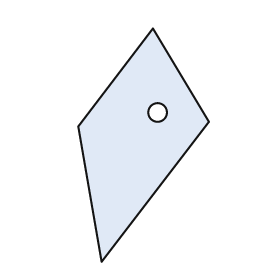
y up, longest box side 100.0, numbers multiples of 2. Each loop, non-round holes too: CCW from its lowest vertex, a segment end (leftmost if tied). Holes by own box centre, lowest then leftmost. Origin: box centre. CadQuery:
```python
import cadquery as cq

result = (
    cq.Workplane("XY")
    .moveTo(-18.0, -50.0)
    .lineTo(28.0, 10.0)
    .lineTo(4.0, 50.0)
    .lineTo(-28.0, 8.0)
    .close()
    .moveTo(6.0, 14.0)
    .circle(4.0)
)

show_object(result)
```